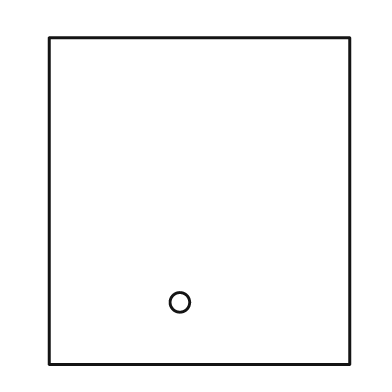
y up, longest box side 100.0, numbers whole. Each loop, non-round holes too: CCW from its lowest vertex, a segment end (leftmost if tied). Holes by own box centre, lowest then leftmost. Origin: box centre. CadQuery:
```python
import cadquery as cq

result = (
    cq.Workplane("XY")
    .moveTo(-46.0, -50.0)
    .lineTo(46.0, -50.0)
    .lineTo(46.0, 50.0)
    .lineTo(-46.0, 50.0)
    .close()
    .moveTo(-6.0, -31.0)
    .circle(3.0)
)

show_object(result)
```